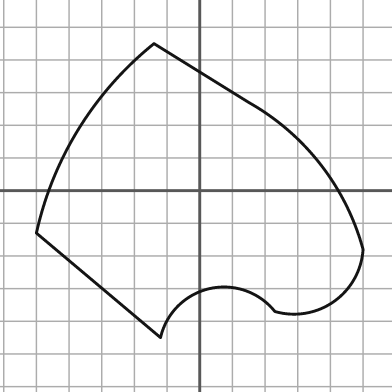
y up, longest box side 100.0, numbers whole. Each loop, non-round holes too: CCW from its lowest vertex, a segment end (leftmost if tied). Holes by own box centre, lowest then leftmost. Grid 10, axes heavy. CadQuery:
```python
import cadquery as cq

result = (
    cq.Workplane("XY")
    .moveTo(-12.0, -45.0)
    .threePointArc((3.0, -30.0), (23.0, -37.0))
    .threePointArc((41.0, -34.0), (50.0, -18.0))
    .threePointArc((37.0, 8.0), (15.0, 27.0))
    .lineTo(-14.0, 45.0)
    .threePointArc((-37.0, 19.0), (-50.0, -13.0))
    .close()
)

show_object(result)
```